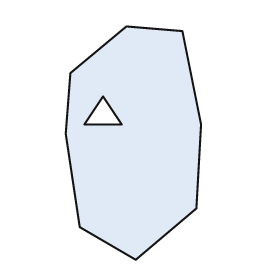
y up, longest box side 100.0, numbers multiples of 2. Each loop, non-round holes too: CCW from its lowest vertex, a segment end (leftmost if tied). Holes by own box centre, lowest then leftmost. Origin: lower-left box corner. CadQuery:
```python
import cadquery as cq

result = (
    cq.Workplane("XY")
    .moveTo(30.0, 0.0)
    .lineTo(56.0, 22.0)
    .lineTo(58.0, 58.0)
    .lineTo(50.0, 98.0)
    .lineTo(26.0, 100.0)
    .lineTo(2.0, 80.0)
    .lineTo(0.0, 54.0)
    .lineTo(6.0, 14.0)
    .close()
    .moveTo(8.0, 58.0)
    .lineTo(24.0, 58.0)
    .lineTo(16.0, 70.0)
    .close()
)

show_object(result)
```